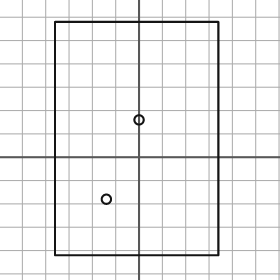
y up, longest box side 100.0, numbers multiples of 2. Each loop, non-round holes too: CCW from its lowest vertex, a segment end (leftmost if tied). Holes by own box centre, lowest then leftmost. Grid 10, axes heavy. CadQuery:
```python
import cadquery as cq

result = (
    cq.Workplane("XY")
    .moveTo(-36.0, -42.0)
    .lineTo(34.0, -42.0)
    .lineTo(34.0, 58.0)
    .lineTo(-36.0, 58.0)
    .close()
    .moveTo(-14.0, -18.0)
    .circle(2.0)
    .moveTo(0.0, 16.0)
    .circle(2.0)
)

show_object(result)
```